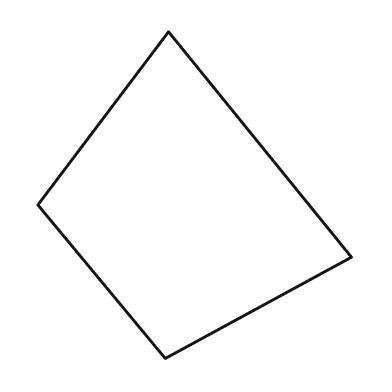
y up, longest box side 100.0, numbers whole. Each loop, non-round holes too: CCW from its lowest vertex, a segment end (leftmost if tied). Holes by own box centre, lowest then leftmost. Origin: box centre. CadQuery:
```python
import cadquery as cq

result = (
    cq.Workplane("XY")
    .moveTo(-9.0, -50.0)
    .lineTo(48.0, -19.0)
    .lineTo(-8.0, 50.0)
    .lineTo(-48.0, -3.0)
    .close()
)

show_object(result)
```